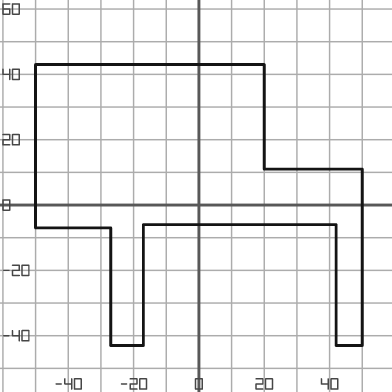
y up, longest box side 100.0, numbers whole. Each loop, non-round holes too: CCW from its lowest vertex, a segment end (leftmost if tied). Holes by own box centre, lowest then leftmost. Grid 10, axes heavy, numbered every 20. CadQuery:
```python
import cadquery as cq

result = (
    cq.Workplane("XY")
    .moveTo(-27.0, -43.0)
    .lineTo(-17.0, -43.0)
    .lineTo(-17.0, -6.0)
    .lineTo(42.0, -6.0)
    .lineTo(42.0, -43.0)
    .lineTo(50.0, -43.0)
    .lineTo(50.0, 11.0)
    .lineTo(20.0, 11.0)
    .lineTo(20.0, 43.0)
    .lineTo(-50.0, 43.0)
    .lineTo(-50.0, -7.0)
    .lineTo(-27.0, -7.0)
    .close()
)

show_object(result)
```